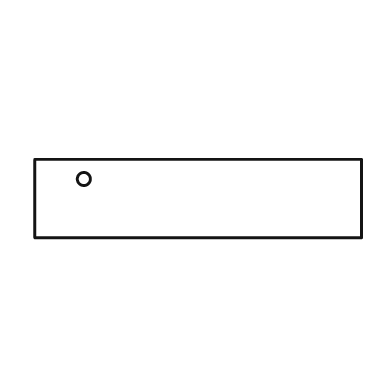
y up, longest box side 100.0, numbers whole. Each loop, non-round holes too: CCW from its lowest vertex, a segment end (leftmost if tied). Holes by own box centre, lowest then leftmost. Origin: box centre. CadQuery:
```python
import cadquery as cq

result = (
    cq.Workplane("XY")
    .moveTo(-50.0, -12.0)
    .lineTo(50.0, -12.0)
    .lineTo(50.0, 12.0)
    .lineTo(-50.0, 12.0)
    .close()
    .moveTo(-35.0, 6.0)
    .circle(2.0)
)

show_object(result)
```